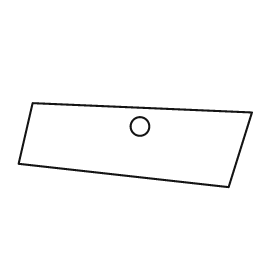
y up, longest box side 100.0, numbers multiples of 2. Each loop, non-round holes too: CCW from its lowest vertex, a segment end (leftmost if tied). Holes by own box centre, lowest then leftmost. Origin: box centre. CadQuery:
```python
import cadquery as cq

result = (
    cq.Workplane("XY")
    .moveTo(40.0, -18.0)
    .lineTo(50.0, 14.0)
    .lineTo(-44.0, 18.0)
    .lineTo(-50.0, -8.0)
    .close()
    .moveTo(2.0, 8.0)
    .circle(4.0)
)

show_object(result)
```